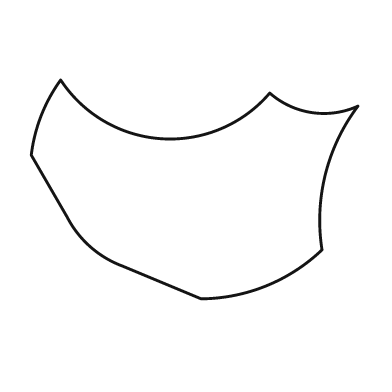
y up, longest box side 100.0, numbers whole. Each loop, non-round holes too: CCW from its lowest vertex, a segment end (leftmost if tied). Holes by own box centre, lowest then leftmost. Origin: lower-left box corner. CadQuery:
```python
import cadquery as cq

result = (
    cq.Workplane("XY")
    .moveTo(52.0, 0.0)
    .threePointArc((72.0, 4.0), (89.0, 15.0))
    .threePointArc((90.0, 38.0), (100.0, 59.0))
    .threePointArc((86.0, 57.0), (73.0, 63.0))
    .threePointArc((40.0, 49.0), (9.0, 67.0))
    .threePointArc((3.0, 56.0), (0.0, 44.0))
    .lineTo(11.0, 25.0)
    .threePointArc((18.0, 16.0), (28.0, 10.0))
    .close()
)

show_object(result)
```